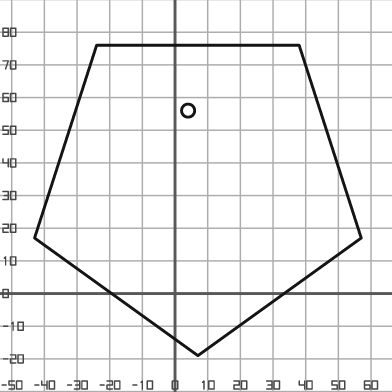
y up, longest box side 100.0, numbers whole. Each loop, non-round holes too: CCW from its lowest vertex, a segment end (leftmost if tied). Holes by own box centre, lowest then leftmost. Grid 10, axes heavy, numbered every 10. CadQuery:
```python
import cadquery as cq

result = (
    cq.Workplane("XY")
    .moveTo(7.0, -19.0)
    .lineTo(57.0, 17.0)
    .lineTo(38.0, 76.0)
    .lineTo(-24.0, 76.0)
    .lineTo(-43.0, 17.0)
    .close()
    .moveTo(4.0, 56.0)
    .circle(2.0)
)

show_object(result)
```